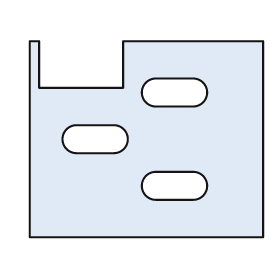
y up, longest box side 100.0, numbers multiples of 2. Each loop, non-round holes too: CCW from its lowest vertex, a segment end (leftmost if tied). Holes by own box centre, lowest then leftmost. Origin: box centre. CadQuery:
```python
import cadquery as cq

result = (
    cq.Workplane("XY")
    .moveTo(-50.0, -42.0)
    .lineTo(50.0, -42.0)
    .lineTo(50.0, 42.0)
    .lineTo(-10.0, 42.0)
    .lineTo(-10.0, 22.0)
    .lineTo(-46.0, 22.0)
    .lineTo(-46.0, 42.0)
    .lineTo(-50.0, 42.0)
    .close()
    .moveTo(4.0, -26.0)
    .lineTo(20.0, -26.0)
    .threePointArc((26.0, -20.0), (20.0, -14.0))
    .lineTo(4.0, -14.0)
    .threePointArc((-2.0, -20.0), (4.0, -26.0))
    .close()
    .moveTo(-30.0, -6.0)
    .lineTo(-14.0, -6.0)
    .threePointArc((-8.0, 0.0), (-14.0, 6.0))
    .lineTo(-30.0, 6.0)
    .threePointArc((-36.0, 0.0), (-30.0, -6.0))
    .close()
    .moveTo(4.0, 14.0)
    .lineTo(20.0, 14.0)
    .threePointArc((26.0, 20.0), (20.0, 26.0))
    .lineTo(4.0, 26.0)
    .threePointArc((-2.0, 20.0), (4.0, 14.0))
    .close()
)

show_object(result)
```